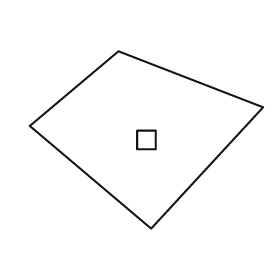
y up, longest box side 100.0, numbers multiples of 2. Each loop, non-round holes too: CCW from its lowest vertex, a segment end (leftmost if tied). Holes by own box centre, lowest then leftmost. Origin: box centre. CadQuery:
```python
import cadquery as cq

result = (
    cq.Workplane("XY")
    .moveTo(2.0, -38.0)
    .lineTo(50.0, 14.0)
    .lineTo(-12.0, 38.0)
    .lineTo(-50.0, 6.0)
    .close()
    .moveTo(-4.0, -4.0)
    .lineTo(4.0, -4.0)
    .lineTo(4.0, 4.0)
    .lineTo(-4.0, 4.0)
    .close()
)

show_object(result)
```